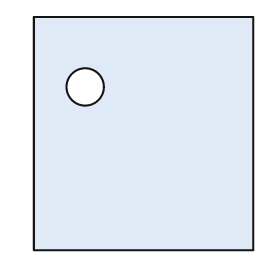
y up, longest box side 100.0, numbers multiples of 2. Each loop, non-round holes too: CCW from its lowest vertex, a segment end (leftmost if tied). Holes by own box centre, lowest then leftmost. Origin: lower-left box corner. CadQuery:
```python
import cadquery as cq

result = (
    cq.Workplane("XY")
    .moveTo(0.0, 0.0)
    .lineTo(94.0, 0.0)
    .lineTo(94.0, 100.0)
    .lineTo(0.0, 100.0)
    .close()
    .moveTo(22.0, 70.0)
    .circle(8.0)
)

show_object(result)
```